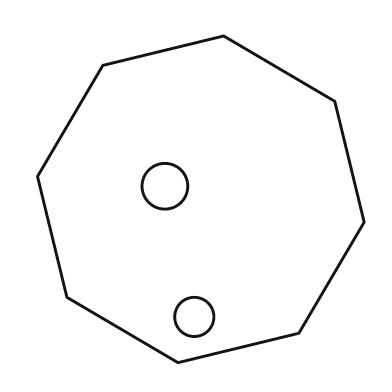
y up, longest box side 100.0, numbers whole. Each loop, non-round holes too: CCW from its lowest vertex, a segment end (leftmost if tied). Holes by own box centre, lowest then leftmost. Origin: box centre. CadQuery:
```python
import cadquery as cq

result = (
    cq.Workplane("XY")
    .moveTo(-7.0, -50.0)
    .lineTo(30.0, -41.0)
    .lineTo(50.0, -7.0)
    .lineTo(41.0, 30.0)
    .lineTo(7.0, 50.0)
    .lineTo(-30.0, 41.0)
    .lineTo(-50.0, 7.0)
    .lineTo(-41.0, -30.0)
    .close()
    .moveTo(-2.0, -36.0)
    .circle(6.0)
    .moveTo(-11.0, 4.0)
    .circle(7.0)
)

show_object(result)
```